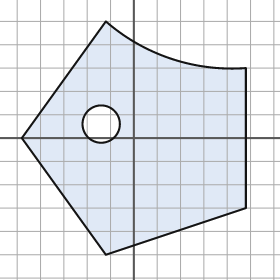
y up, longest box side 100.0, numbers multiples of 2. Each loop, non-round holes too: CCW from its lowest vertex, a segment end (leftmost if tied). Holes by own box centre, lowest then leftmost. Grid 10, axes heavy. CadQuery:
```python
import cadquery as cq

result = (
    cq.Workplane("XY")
    .moveTo(-12.0, -50.0)
    .lineTo(48.0, -30.0)
    .lineTo(48.0, 30.0)
    .threePointArc((16.0, 34.0), (-12.0, 50.0))
    .lineTo(-48.0, 0.0)
    .close()
    .moveTo(-14.0, 6.0)
    .circle(8.0)
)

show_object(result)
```